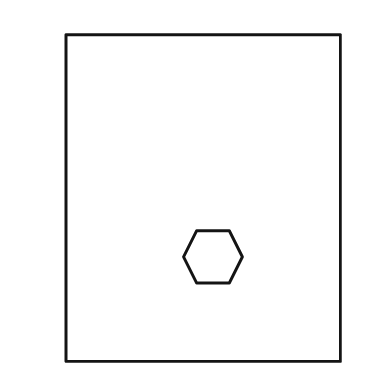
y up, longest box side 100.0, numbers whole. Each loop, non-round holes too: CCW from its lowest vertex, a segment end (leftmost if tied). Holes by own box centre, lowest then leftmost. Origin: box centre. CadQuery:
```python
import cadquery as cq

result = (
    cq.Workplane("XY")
    .moveTo(-42.0, -50.0)
    .lineTo(42.0, -50.0)
    .lineTo(42.0, 50.0)
    .lineTo(-42.0, 50.0)
    .close()
    .moveTo(-2.0, -26.0)
    .lineTo(8.0, -26.0)
    .lineTo(12.0, -18.0)
    .lineTo(8.0, -10.0)
    .lineTo(-2.0, -10.0)
    .lineTo(-6.0, -18.0)
    .close()
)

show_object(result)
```